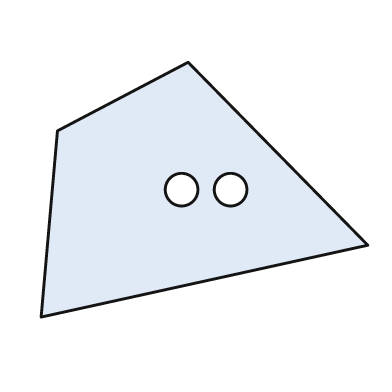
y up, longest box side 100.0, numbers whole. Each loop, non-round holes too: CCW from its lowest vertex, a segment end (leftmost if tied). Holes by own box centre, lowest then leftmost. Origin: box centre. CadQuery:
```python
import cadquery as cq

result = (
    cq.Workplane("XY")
    .moveTo(-50.0, -39.0)
    .lineTo(50.0, -17.0)
    .lineTo(-5.0, 39.0)
    .lineTo(-45.0, 18.0)
    .close()
    .moveTo(-7.0, 0.0)
    .circle(5.0)
    .moveTo(8.0, 0.0)
    .circle(5.0)
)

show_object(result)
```